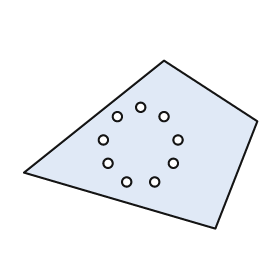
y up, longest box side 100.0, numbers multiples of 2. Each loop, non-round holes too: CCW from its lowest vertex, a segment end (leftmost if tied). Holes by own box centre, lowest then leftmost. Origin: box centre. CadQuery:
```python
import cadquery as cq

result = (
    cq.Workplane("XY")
    .moveTo(32.0, -36.0)
    .lineTo(50.0, 10.0)
    .lineTo(10.0, 36.0)
    .lineTo(-50.0, -12.0)
    .close()
    .moveTo(-6.0, -16.0)
    .circle(2.0)
    .moveTo(6.0, -16.0)
    .circle(2.0)
    .moveTo(-14.0, -8.0)
    .circle(2.0)
    .moveTo(14.0, -8.0)
    .circle(2.0)
    .moveTo(-16.0, 2.0)
    .circle(2.0)
    .moveTo(16.0, 2.0)
    .circle(2.0)
    .moveTo(-10.0, 12.0)
    .circle(2.0)
    .moveTo(10.0, 12.0)
    .circle(2.0)
    .moveTo(0.0, 16.0)
    .circle(2.0)
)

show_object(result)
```